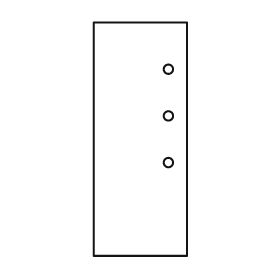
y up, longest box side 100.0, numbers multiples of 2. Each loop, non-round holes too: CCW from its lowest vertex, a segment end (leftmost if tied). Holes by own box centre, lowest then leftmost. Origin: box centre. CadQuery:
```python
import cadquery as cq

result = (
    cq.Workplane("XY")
    .moveTo(-20.0, -50.0)
    .lineTo(20.0, -50.0)
    .lineTo(20.0, 50.0)
    .lineTo(-20.0, 50.0)
    .close()
    .moveTo(12.0, -10.0)
    .circle(2.0)
    .moveTo(12.0, 10.0)
    .circle(2.0)
    .moveTo(12.0, 30.0)
    .circle(2.0)
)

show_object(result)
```